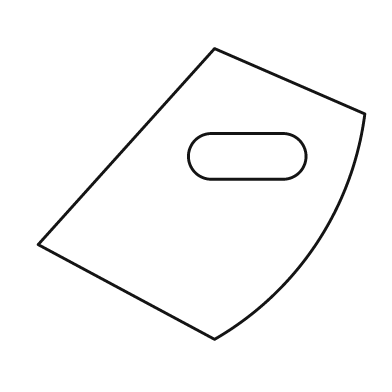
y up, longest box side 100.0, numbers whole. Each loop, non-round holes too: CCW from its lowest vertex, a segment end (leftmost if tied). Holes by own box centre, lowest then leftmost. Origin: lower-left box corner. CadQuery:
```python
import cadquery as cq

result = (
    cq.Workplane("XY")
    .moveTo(54.0, 0.0)
    .threePointArc((85.0, 29.0), (100.0, 69.0))
    .lineTo(54.0, 89.0)
    .lineTo(0.0, 29.0)
    .close()
    .moveTo(53.0, 49.0)
    .lineTo(75.0, 49.0)
    .threePointArc((82.0, 56.0), (75.0, 63.0))
    .lineTo(53.0, 63.0)
    .threePointArc((46.0, 56.0), (53.0, 49.0))
    .close()
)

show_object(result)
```